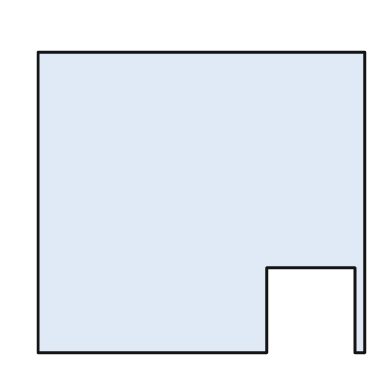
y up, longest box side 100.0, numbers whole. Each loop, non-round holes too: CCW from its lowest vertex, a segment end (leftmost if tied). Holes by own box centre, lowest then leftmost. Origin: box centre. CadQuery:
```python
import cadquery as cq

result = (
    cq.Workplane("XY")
    .moveTo(-50.0, -46.0)
    .lineTo(20.0, -46.0)
    .lineTo(20.0, -20.0)
    .lineTo(47.0, -20.0)
    .lineTo(47.0, -46.0)
    .lineTo(50.0, -46.0)
    .lineTo(50.0, 46.0)
    .lineTo(-50.0, 46.0)
    .close()
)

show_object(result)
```